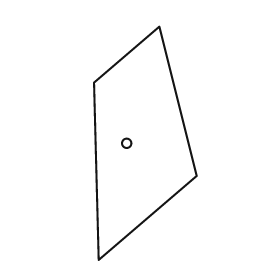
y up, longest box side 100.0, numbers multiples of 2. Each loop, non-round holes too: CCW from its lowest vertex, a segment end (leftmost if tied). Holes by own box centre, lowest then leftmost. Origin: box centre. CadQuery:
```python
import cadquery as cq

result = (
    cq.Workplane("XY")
    .moveTo(-20.0, -50.0)
    .lineTo(22.0, -14.0)
    .lineTo(6.0, 50.0)
    .lineTo(-22.0, 26.0)
    .close()
    .moveTo(-8.0, 0.0)
    .circle(2.0)
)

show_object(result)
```